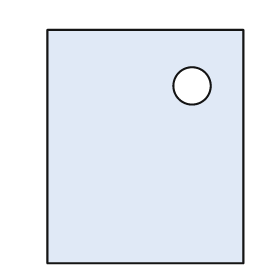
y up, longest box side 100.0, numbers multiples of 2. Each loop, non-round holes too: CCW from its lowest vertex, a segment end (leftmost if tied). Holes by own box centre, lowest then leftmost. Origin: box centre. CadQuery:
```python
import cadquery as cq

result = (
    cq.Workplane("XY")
    .moveTo(-42.0, -50.0)
    .lineTo(42.0, -50.0)
    .lineTo(42.0, 50.0)
    .lineTo(-42.0, 50.0)
    .close()
    .moveTo(20.0, 26.0)
    .circle(8.0)
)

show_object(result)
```